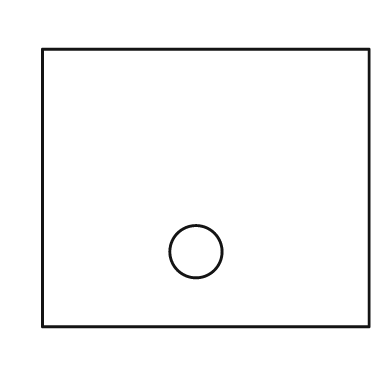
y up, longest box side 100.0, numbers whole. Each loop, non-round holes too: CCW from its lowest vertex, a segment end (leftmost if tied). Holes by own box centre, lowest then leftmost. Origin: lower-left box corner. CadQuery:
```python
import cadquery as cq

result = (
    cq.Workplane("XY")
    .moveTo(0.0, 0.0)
    .lineTo(100.0, 0.0)
    .lineTo(100.0, 85.0)
    .lineTo(0.0, 85.0)
    .close()
    .moveTo(47.0, 23.0)
    .circle(8.0)
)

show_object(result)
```